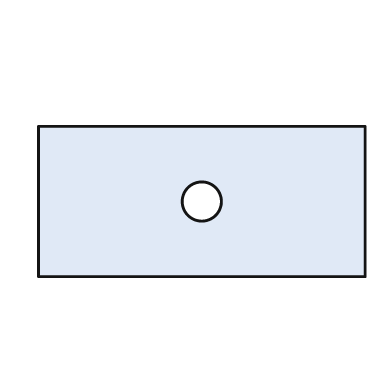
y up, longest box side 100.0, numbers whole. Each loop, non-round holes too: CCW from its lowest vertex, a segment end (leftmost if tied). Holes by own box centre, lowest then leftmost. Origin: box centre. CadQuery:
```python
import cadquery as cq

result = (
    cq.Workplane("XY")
    .moveTo(-50.0, -23.0)
    .lineTo(50.0, -23.0)
    .lineTo(50.0, 23.0)
    .lineTo(-50.0, 23.0)
    .close()
    .moveTo(0.0, 0.0)
    .circle(6.0)
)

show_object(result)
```